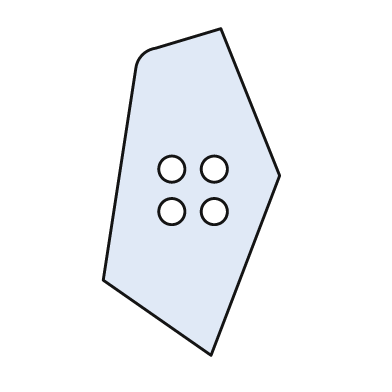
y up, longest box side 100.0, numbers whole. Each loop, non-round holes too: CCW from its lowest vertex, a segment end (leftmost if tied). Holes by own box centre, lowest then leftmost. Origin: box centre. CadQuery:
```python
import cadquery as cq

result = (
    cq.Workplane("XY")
    .moveTo(6.0, -50.0)
    .lineTo(27.0, 5.0)
    .lineTo(9.0, 50.0)
    .lineTo(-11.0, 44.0)
    .threePointArc((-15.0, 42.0), (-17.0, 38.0))
    .lineTo(-27.0, -27.0)
    .close()
    .moveTo(-6.0, -6.0)
    .circle(4.0)
    .moveTo(7.0, -6.0)
    .circle(4.0)
    .moveTo(-6.0, 7.0)
    .circle(4.0)
    .moveTo(7.0, 7.0)
    .circle(4.0)
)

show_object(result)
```